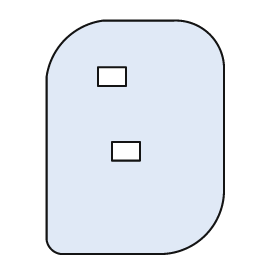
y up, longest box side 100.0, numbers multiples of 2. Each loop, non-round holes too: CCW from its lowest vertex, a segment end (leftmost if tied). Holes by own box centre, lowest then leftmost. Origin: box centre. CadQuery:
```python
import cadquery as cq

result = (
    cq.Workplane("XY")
    .moveTo(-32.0, -50.0)
    .lineTo(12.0, -50.0)
    .threePointArc((30.0, -42.0), (38.0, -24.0))
    .lineTo(38.0, 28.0)
    .threePointArc((32.0, 44.0), (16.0, 50.0))
    .lineTo(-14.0, 50.0)
    .threePointArc((-30.0, 42.0), (-38.0, 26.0))
    .lineTo(-38.0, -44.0)
    .threePointArc((-36.0, -48.0), (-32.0, -50.0))
    .close()
    .moveTo(-10.0, -10.0)
    .lineTo(2.0, -10.0)
    .lineTo(2.0, -2.0)
    .lineTo(-10.0, -2.0)
    .close()
    .moveTo(-16.0, 22.0)
    .lineTo(-4.0, 22.0)
    .lineTo(-4.0, 30.0)
    .lineTo(-16.0, 30.0)
    .close()
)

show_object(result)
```